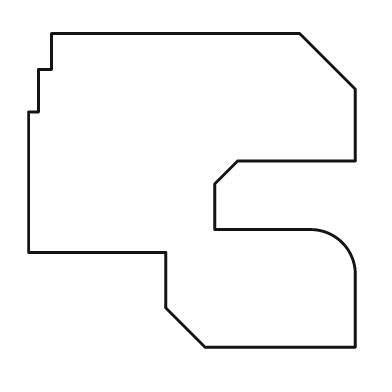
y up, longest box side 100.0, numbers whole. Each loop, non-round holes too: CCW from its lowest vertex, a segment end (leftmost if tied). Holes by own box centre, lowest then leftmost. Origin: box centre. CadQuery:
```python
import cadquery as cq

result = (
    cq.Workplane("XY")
    .moveTo(4.0, -48.0)
    .lineTo(50.0, -48.0)
    .lineTo(50.0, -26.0)
    .threePointArc((46.0, -16.0), (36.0, -12.0))
    .lineTo(7.0, -12.0)
    .lineTo(7.0, 2.0)
    .lineTo(14.0, 9.0)
    .lineTo(50.0, 9.0)
    .lineTo(50.0, 31.0)
    .lineTo(33.0, 48.0)
    .lineTo(-43.0, 48.0)
    .lineTo(-43.0, 37.0)
    .lineTo(-47.0, 37.0)
    .lineTo(-47.0, 24.0)
    .lineTo(-50.0, 24.0)
    .lineTo(-50.0, -19.0)
    .lineTo(-8.0, -19.0)
    .lineTo(-8.0, -36.0)
    .close()
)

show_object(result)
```